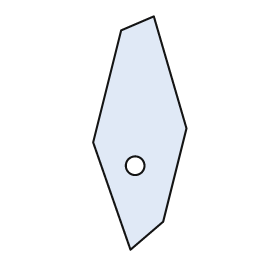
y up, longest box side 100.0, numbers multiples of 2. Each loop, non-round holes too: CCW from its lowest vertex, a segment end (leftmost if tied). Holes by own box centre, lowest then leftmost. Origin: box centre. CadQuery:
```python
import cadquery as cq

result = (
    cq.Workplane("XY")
    .moveTo(-4.0, -50.0)
    .lineTo(10.0, -38.0)
    .lineTo(20.0, 2.0)
    .lineTo(6.0, 50.0)
    .lineTo(-8.0, 44.0)
    .lineTo(-20.0, -4.0)
    .close()
    .moveTo(-2.0, -14.0)
    .circle(4.0)
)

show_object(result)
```